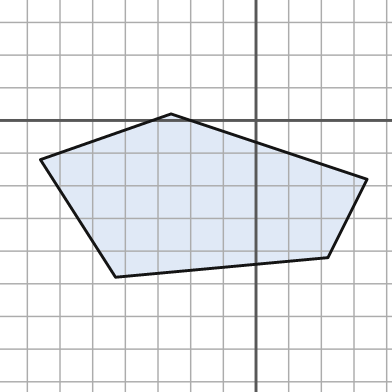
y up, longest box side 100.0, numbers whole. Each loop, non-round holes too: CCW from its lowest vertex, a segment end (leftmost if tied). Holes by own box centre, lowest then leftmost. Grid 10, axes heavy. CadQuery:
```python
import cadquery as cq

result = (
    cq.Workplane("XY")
    .moveTo(-43.0, -48.0)
    .lineTo(22.0, -42.0)
    .lineTo(34.0, -18.0)
    .lineTo(-26.0, 2.0)
    .lineTo(-66.0, -12.0)
    .close()
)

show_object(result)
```